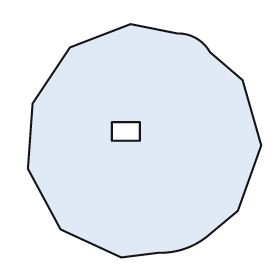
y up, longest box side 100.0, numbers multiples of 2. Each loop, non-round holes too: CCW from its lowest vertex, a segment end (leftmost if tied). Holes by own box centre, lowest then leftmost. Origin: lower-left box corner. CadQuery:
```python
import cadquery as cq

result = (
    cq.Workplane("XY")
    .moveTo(40.0, 0.0)
    .lineTo(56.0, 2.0)
    .threePointArc((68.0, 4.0), (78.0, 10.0))
    .lineTo(90.0, 20.0)
    .lineTo(100.0, 48.0)
    .lineTo(92.0, 76.0)
    .lineTo(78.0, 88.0)
    .threePointArc((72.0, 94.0), (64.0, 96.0))
    .lineTo(44.0, 100.0)
    .lineTo(18.0, 90.0)
    .lineTo(2.0, 66.0)
    .lineTo(0.0, 38.0)
    .lineTo(14.0, 12.0)
    .close()
    .moveTo(36.0, 50.0)
    .lineTo(48.0, 50.0)
    .lineTo(48.0, 58.0)
    .lineTo(36.0, 58.0)
    .close()
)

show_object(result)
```